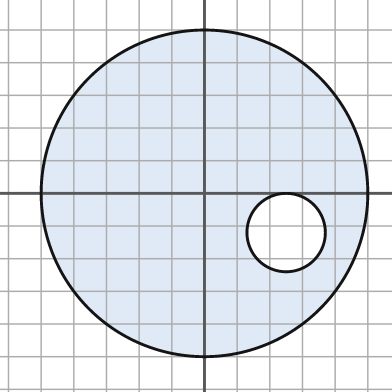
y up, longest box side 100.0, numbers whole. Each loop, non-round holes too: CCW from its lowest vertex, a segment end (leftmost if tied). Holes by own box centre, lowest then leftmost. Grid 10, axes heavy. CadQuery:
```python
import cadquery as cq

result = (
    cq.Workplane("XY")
    .moveTo(0.0, 0.0)
    .circle(50.0)
    .moveTo(25.0, -12.0)
    .circle(12.0)
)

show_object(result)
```